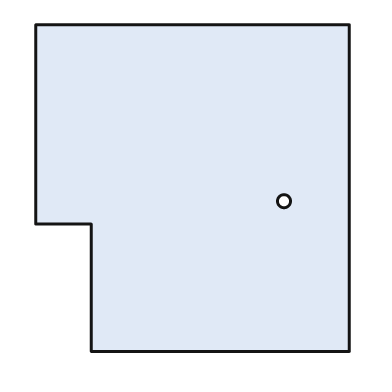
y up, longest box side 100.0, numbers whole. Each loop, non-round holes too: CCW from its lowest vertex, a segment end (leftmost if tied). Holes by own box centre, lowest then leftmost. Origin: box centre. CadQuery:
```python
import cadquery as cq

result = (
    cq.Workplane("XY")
    .moveTo(-31.0, -50.0)
    .lineTo(48.0, -50.0)
    .lineTo(48.0, 50.0)
    .lineTo(-48.0, 50.0)
    .lineTo(-48.0, -11.0)
    .lineTo(-31.0, -11.0)
    .close()
    .moveTo(28.0, -4.0)
    .circle(2.0)
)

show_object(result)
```